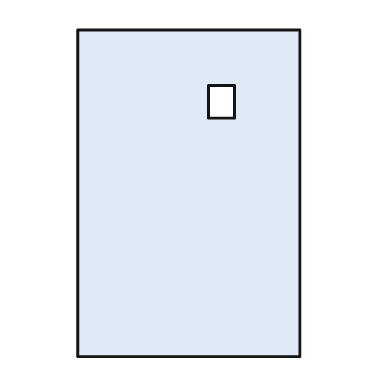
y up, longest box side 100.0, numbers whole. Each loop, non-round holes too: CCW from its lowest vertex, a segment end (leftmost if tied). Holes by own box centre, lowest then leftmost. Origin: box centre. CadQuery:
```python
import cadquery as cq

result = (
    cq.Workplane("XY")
    .moveTo(-34.0, -50.0)
    .lineTo(34.0, -50.0)
    .lineTo(34.0, 50.0)
    .lineTo(-34.0, 50.0)
    .close()
    .moveTo(6.0, 23.0)
    .lineTo(14.0, 23.0)
    .lineTo(14.0, 33.0)
    .lineTo(6.0, 33.0)
    .close()
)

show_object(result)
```